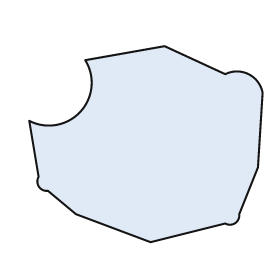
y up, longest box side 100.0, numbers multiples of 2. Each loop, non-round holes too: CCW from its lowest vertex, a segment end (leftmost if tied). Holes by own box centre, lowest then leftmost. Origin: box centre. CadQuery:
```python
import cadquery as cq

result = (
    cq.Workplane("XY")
    .moveTo(2.0, -42.0)
    .lineTo(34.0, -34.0)
    .threePointArc((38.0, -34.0), (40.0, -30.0))
    .lineTo(48.0, -10.0)
    .lineTo(50.0, 22.0)
    .threePointArc((44.0, 30.0), (34.0, 30.0))
    .lineTo(8.0, 42.0)
    .lineTo(-26.0, 36.0)
    .threePointArc((-28.0, 14.0), (-50.0, 10.0))
    .lineTo(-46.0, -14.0)
    .threePointArc((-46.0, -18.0), (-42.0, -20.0))
    .lineTo(-30.0, -30.0)
    .close()
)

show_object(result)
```